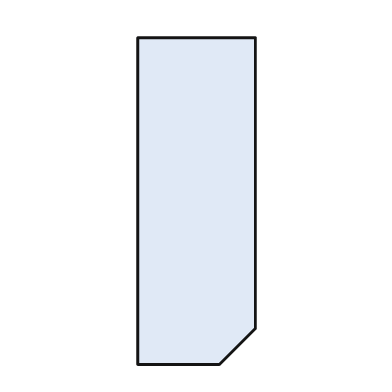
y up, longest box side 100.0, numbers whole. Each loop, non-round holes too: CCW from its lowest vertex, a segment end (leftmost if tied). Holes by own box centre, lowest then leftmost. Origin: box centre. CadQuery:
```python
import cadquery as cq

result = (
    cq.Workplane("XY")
    .moveTo(-18.0, -50.0)
    .lineTo(7.0, -50.0)
    .lineTo(18.0, -39.0)
    .lineTo(18.0, 50.0)
    .lineTo(-18.0, 50.0)
    .close()
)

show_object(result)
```